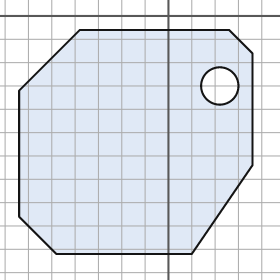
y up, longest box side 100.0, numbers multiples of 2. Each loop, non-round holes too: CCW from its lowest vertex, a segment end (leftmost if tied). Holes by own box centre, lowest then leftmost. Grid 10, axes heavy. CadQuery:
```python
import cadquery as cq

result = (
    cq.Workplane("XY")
    .moveTo(-48.0, -102.0)
    .lineTo(10.0, -102.0)
    .lineTo(36.0, -64.0)
    .lineTo(36.0, -16.0)
    .lineTo(26.0, -6.0)
    .lineTo(-38.0, -6.0)
    .lineTo(-64.0, -32.0)
    .lineTo(-64.0, -86.0)
    .close()
    .moveTo(22.0, -30.0)
    .circle(8.0)
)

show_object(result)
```